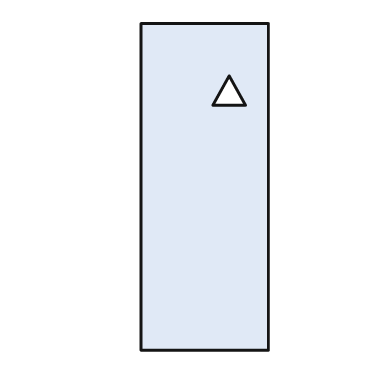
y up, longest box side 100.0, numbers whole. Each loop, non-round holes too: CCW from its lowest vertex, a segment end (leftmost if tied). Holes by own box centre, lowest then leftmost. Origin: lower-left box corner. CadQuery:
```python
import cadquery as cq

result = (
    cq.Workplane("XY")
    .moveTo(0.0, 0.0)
    .lineTo(39.0, 0.0)
    .lineTo(39.0, 100.0)
    .lineTo(0.0, 100.0)
    .close()
    .moveTo(22.0, 75.0)
    .lineTo(32.0, 75.0)
    .lineTo(27.0, 84.0)
    .close()
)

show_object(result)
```